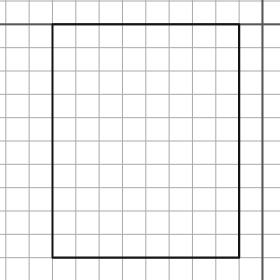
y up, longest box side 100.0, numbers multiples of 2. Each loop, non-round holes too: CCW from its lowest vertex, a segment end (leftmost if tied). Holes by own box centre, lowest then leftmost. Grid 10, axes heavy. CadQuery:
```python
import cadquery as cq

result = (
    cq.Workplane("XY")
    .moveTo(-90.0, -100.0)
    .lineTo(-10.0, -100.0)
    .lineTo(-10.0, 0.0)
    .lineTo(-90.0, 0.0)
    .close()
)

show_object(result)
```